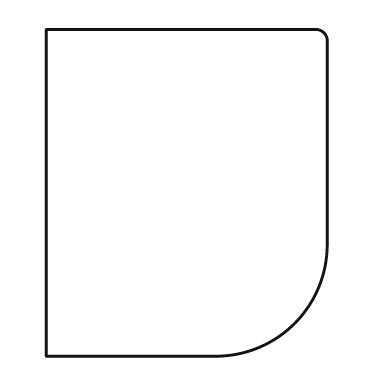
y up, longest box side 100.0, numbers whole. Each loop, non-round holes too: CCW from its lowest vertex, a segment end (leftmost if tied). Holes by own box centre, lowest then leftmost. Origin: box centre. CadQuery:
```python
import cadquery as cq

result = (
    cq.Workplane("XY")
    .moveTo(-43.0, -50.0)
    .lineTo(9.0, -50.0)
    .threePointArc((33.0, -40.0), (43.0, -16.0))
    .lineTo(43.0, 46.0)
    .threePointArc((42.0, 49.0), (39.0, 50.0))
    .lineTo(-43.0, 50.0)
    .close()
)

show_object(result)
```